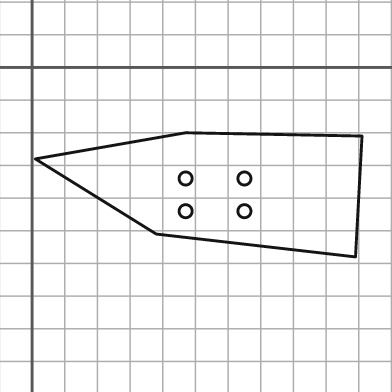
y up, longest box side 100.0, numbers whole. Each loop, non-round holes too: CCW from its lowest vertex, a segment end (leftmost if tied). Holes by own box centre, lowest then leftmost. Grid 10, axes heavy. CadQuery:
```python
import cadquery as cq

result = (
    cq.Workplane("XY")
    .moveTo(99.0, -58.0)
    .lineTo(101.0, -21.0)
    .lineTo(47.0, -20.0)
    .lineTo(1.0, -28.0)
    .lineTo(38.0, -51.0)
    .close()
    .moveTo(47.0, -44.0)
    .circle(2.0)
    .moveTo(65.0, -44.0)
    .circle(2.0)
    .moveTo(47.0, -34.0)
    .circle(2.0)
    .moveTo(65.0, -34.0)
    .circle(2.0)
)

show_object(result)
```